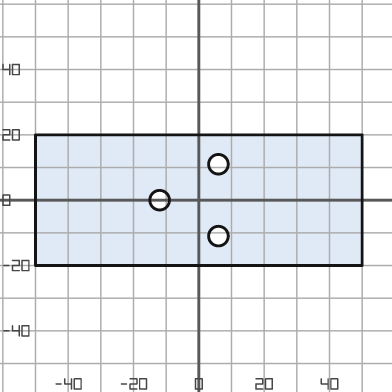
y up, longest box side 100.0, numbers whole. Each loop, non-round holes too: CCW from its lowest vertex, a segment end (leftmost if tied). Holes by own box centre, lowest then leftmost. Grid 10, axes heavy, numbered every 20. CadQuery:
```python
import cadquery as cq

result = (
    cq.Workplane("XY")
    .moveTo(-50.0, -20.0)
    .lineTo(50.0, -20.0)
    .lineTo(50.0, 20.0)
    .lineTo(-50.0, 20.0)
    .close()
    .moveTo(6.0, -11.0)
    .circle(3.0)
    .moveTo(-12.0, 0.0)
    .circle(3.0)
    .moveTo(6.0, 11.0)
    .circle(3.0)
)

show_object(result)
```